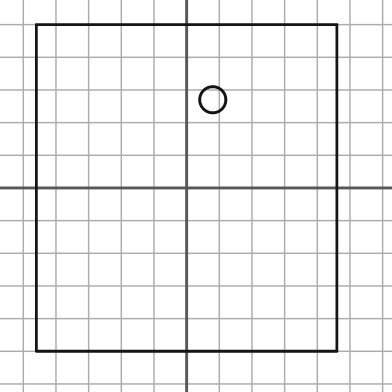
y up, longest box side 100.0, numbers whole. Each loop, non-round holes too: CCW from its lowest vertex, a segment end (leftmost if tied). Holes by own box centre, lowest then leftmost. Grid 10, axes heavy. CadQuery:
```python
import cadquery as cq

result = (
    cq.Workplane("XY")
    .moveTo(-46.0, -50.0)
    .lineTo(46.0, -50.0)
    .lineTo(46.0, 50.0)
    .lineTo(-46.0, 50.0)
    .close()
    .moveTo(8.0, 27.0)
    .circle(4.0)
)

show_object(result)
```